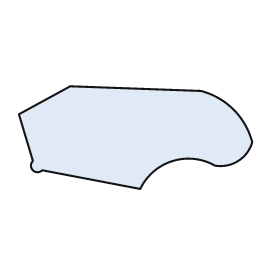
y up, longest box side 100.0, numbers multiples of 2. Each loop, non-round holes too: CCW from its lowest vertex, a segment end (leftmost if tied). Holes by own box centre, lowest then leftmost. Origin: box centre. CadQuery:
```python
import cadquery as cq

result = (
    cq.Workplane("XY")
    .moveTo(2.0, -22.0)
    .threePointArc((16.0, -10.0), (34.0, -12.0))
    .threePointArc((44.0, -10.0), (50.0, -2.0))
    .threePointArc((42.0, 12.0), (28.0, 20.0))
    .lineTo(-28.0, 22.0)
    .lineTo(-50.0, 10.0)
    .lineTo(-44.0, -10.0)
    .threePointArc((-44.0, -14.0), (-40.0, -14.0))
    .close()
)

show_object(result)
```